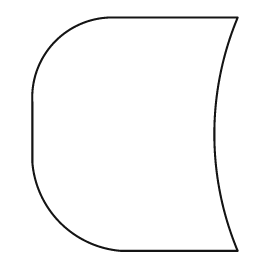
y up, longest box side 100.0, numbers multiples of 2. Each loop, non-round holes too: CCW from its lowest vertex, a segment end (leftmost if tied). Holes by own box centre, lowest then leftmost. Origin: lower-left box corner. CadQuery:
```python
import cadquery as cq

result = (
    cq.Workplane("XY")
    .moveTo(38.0, 0.0)
    .lineTo(88.0, 0.0)
    .threePointArc((78.0, 50.0), (88.0, 100.0))
    .lineTo(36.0, 100.0)
    .threePointArc((10.0, 90.0), (0.0, 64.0))
    .lineTo(0.0, 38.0)
    .threePointArc((12.0, 12.0), (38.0, 0.0))
    .close()
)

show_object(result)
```